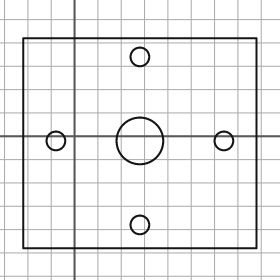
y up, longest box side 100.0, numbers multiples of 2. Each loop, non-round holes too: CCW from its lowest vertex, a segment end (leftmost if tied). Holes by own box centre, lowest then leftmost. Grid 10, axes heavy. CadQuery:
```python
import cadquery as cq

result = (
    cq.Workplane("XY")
    .moveTo(-22.0, -48.0)
    .lineTo(78.0, -48.0)
    .lineTo(78.0, 42.0)
    .lineTo(-22.0, 42.0)
    .close()
    .moveTo(28.0, -38.0)
    .circle(4.0)
    .moveTo(-8.0, -2.0)
    .circle(4.0)
    .moveTo(28.0, -2.0)
    .circle(10.0)
    .moveTo(64.0, -2.0)
    .circle(4.0)
    .moveTo(28.0, 34.0)
    .circle(4.0)
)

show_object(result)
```